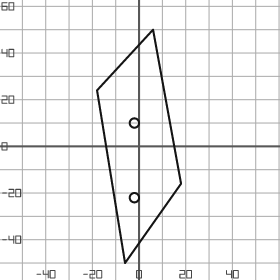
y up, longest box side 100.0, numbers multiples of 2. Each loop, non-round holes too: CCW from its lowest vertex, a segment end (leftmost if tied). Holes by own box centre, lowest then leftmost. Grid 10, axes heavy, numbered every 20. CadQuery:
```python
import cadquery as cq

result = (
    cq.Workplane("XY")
    .moveTo(-6.0, -50.0)
    .lineTo(18.0, -16.0)
    .lineTo(6.0, 50.0)
    .lineTo(-18.0, 24.0)
    .close()
    .moveTo(-2.0, -22.0)
    .circle(2.0)
    .moveTo(-2.0, 10.0)
    .circle(2.0)
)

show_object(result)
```